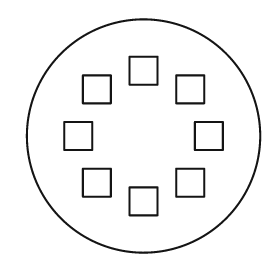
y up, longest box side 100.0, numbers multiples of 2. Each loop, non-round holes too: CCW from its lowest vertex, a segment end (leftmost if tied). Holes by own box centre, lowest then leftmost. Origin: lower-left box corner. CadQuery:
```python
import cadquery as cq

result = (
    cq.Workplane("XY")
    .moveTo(50.0, 50.0)
    .circle(50.0)
    .moveTo(44.0, 16.0)
    .lineTo(56.0, 16.0)
    .lineTo(56.0, 28.0)
    .lineTo(44.0, 28.0)
    .close()
    .moveTo(24.0, 24.0)
    .lineTo(36.0, 24.0)
    .lineTo(36.0, 36.0)
    .lineTo(24.0, 36.0)
    .close()
    .moveTo(64.0, 24.0)
    .lineTo(76.0, 24.0)
    .lineTo(76.0, 36.0)
    .lineTo(64.0, 36.0)
    .close()
    .moveTo(16.0, 44.0)
    .lineTo(28.0, 44.0)
    .lineTo(28.0, 56.0)
    .lineTo(16.0, 56.0)
    .close()
    .moveTo(72.0, 44.0)
    .lineTo(84.0, 44.0)
    .lineTo(84.0, 56.0)
    .lineTo(72.0, 56.0)
    .close()
    .moveTo(24.0, 64.0)
    .lineTo(36.0, 64.0)
    .lineTo(36.0, 76.0)
    .lineTo(24.0, 76.0)
    .close()
    .moveTo(64.0, 64.0)
    .lineTo(76.0, 64.0)
    .lineTo(76.0, 76.0)
    .lineTo(64.0, 76.0)
    .close()
    .moveTo(44.0, 72.0)
    .lineTo(56.0, 72.0)
    .lineTo(56.0, 84.0)
    .lineTo(44.0, 84.0)
    .close()
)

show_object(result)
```